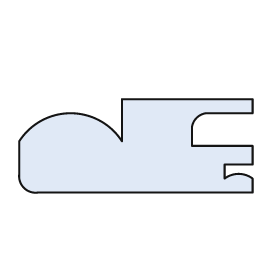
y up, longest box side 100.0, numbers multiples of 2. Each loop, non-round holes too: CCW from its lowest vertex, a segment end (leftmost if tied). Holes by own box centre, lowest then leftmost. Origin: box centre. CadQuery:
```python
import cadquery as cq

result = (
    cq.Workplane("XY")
    .moveTo(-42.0, -20.0)
    .lineTo(50.0, -20.0)
    .lineTo(50.0, -14.0)
    .threePointArc((44.0, -12.0), (38.0, -14.0))
    .lineTo(38.0, -8.0)
    .lineTo(50.0, -8.0)
    .lineTo(50.0, 0.0)
    .lineTo(24.0, 0.0)
    .lineTo(24.0, 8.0)
    .threePointArc((26.0, 12.0), (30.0, 14.0))
    .lineTo(50.0, 14.0)
    .lineTo(50.0, 20.0)
    .lineTo(-6.0, 20.0)
    .lineTo(-6.0, 2.0)
    .threePointArc((-28.0, 14.0), (-50.0, 2.0))
    .lineTo(-50.0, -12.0)
    .threePointArc((-48.0, -18.0), (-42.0, -20.0))
    .close()
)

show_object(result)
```